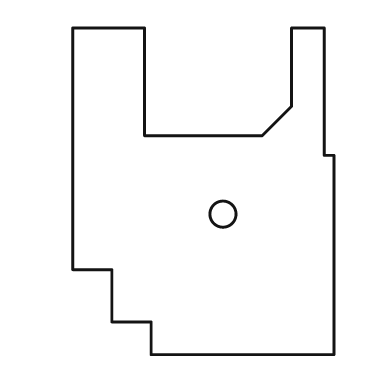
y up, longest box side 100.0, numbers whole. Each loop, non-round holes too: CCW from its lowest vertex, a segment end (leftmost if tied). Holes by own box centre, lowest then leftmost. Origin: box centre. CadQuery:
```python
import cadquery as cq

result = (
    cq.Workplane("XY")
    .moveTo(-16.0, -50.0)
    .lineTo(40.0, -50.0)
    .lineTo(40.0, 11.0)
    .lineTo(37.0, 11.0)
    .lineTo(37.0, 50.0)
    .lineTo(27.0, 50.0)
    .lineTo(27.0, 26.0)
    .lineTo(18.0, 17.0)
    .lineTo(-18.0, 17.0)
    .lineTo(-18.0, 50.0)
    .lineTo(-40.0, 50.0)
    .lineTo(-40.0, -24.0)
    .lineTo(-28.0, -24.0)
    .lineTo(-28.0, -40.0)
    .lineTo(-16.0, -40.0)
    .close()
    .moveTo(6.0, -7.0)
    .circle(4.0)
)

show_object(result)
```